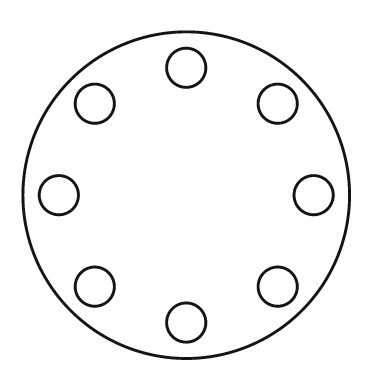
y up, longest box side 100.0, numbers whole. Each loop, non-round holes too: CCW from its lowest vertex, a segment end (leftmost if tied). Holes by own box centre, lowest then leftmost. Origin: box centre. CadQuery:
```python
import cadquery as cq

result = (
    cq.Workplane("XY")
    .moveTo(0.0, 0.0)
    .circle(50.0)
    .moveTo(0.0, -39.0)
    .circle(6.0)
    .moveTo(-28.0, -28.0)
    .circle(6.0)
    .moveTo(28.0, -28.0)
    .circle(6.0)
    .moveTo(-39.0, 0.0)
    .circle(6.0)
    .moveTo(39.0, 0.0)
    .circle(6.0)
    .moveTo(-28.0, 28.0)
    .circle(6.0)
    .moveTo(28.0, 28.0)
    .circle(6.0)
    .moveTo(0.0, 39.0)
    .circle(6.0)
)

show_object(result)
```